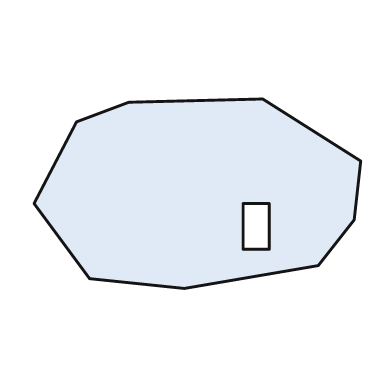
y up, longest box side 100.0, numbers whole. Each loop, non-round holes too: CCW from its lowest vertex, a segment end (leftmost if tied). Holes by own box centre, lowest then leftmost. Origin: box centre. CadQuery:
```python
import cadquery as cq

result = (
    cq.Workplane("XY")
    .moveTo(-4.0, -29.0)
    .lineTo(37.0, -22.0)
    .lineTo(48.0, -8.0)
    .lineTo(50.0, 10.0)
    .lineTo(20.0, 29.0)
    .lineTo(-21.0, 28.0)
    .lineTo(-37.0, 22.0)
    .lineTo(-50.0, -3.0)
    .lineTo(-33.0, -26.0)
    .close()
    .moveTo(14.0, -17.0)
    .lineTo(22.0, -17.0)
    .lineTo(22.0, -3.0)
    .lineTo(14.0, -3.0)
    .close()
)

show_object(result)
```